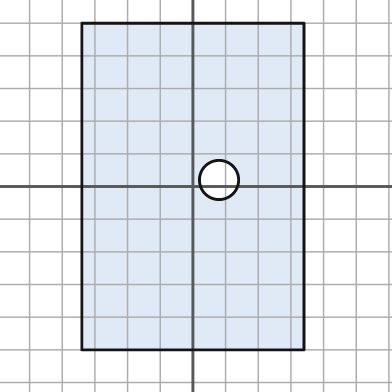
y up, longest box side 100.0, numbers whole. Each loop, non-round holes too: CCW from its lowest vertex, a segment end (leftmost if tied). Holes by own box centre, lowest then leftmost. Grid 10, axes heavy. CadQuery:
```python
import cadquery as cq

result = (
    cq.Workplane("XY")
    .moveTo(-34.0, -50.0)
    .lineTo(34.0, -50.0)
    .lineTo(34.0, 50.0)
    .lineTo(-34.0, 50.0)
    .close()
    .moveTo(8.0, 2.0)
    .circle(6.0)
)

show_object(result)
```